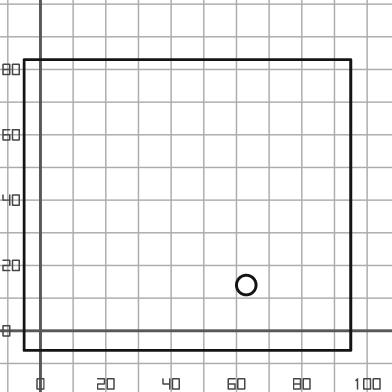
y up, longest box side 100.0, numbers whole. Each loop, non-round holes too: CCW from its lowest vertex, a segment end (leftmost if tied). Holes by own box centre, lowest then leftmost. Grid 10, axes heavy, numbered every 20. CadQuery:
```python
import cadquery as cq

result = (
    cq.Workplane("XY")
    .moveTo(-5.0, -6.0)
    .lineTo(95.0, -6.0)
    .lineTo(95.0, 83.0)
    .lineTo(-5.0, 83.0)
    .close()
    .moveTo(63.0, 14.0)
    .circle(3.0)
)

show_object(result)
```